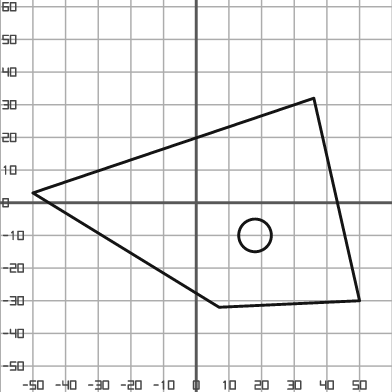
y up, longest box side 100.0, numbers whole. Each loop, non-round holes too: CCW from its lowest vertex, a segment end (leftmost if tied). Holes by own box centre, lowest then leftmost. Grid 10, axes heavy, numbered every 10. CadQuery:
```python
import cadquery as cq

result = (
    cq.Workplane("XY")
    .moveTo(7.0, -32.0)
    .lineTo(50.0, -30.0)
    .lineTo(36.0, 32.0)
    .lineTo(-50.0, 3.0)
    .close()
    .moveTo(18.0, -10.0)
    .circle(5.0)
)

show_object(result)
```